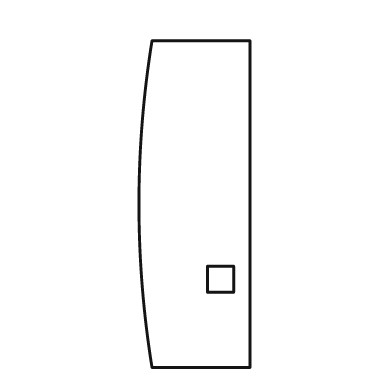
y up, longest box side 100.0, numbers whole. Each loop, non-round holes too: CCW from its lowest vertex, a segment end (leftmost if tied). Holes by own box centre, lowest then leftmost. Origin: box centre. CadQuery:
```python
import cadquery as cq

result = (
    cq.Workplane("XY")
    .moveTo(-13.0, -50.0)
    .lineTo(17.0, -50.0)
    .lineTo(17.0, 50.0)
    .lineTo(-13.0, 50.0)
    .threePointArc((-17.0, 0.0), (-13.0, -50.0))
    .close()
    .moveTo(4.0, -27.0)
    .lineTo(12.0, -27.0)
    .lineTo(12.0, -19.0)
    .lineTo(4.0, -19.0)
    .close()
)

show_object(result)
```